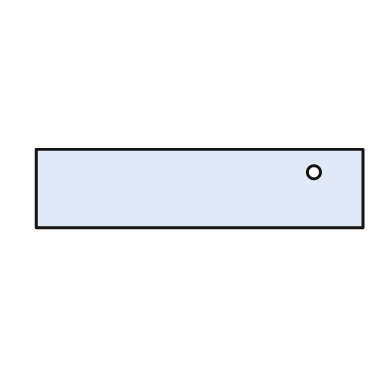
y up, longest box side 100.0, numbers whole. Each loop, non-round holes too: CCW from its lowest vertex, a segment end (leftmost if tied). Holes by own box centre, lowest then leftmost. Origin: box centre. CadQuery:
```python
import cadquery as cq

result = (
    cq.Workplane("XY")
    .moveTo(-50.0, -12.0)
    .lineTo(50.0, -12.0)
    .lineTo(50.0, 12.0)
    .lineTo(-50.0, 12.0)
    .close()
    .moveTo(35.0, 5.0)
    .circle(2.0)
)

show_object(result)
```